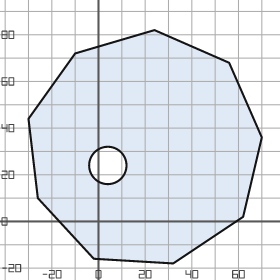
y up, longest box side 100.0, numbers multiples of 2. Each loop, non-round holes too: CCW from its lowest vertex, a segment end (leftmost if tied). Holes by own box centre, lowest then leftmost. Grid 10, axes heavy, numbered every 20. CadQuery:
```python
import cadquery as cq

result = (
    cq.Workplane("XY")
    .moveTo(32.0, -18.0)
    .lineTo(62.0, 2.0)
    .lineTo(70.0, 36.0)
    .lineTo(56.0, 68.0)
    .lineTo(24.0, 82.0)
    .lineTo(-10.0, 72.0)
    .lineTo(-30.0, 44.0)
    .lineTo(-26.0, 10.0)
    .lineTo(-2.0, -16.0)
    .close()
    .moveTo(4.0, 24.0)
    .circle(8.0)
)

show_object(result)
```